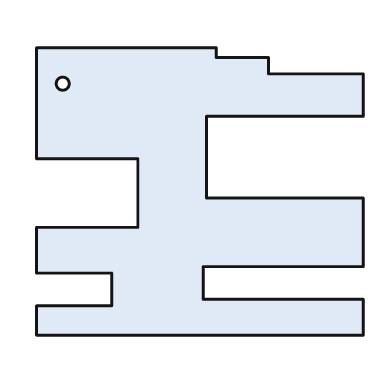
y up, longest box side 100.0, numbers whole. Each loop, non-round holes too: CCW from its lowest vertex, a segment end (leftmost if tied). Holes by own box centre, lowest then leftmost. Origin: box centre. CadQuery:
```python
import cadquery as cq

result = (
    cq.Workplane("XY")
    .moveTo(-50.0, -44.0)
    .lineTo(50.0, -44.0)
    .lineTo(50.0, -33.0)
    .lineTo(1.0, -33.0)
    .lineTo(1.0, -23.0)
    .lineTo(50.0, -23.0)
    .lineTo(50.0, -2.0)
    .lineTo(2.0, -2.0)
    .lineTo(2.0, 23.0)
    .lineTo(50.0, 23.0)
    .lineTo(50.0, 36.0)
    .lineTo(21.0, 36.0)
    .lineTo(21.0, 41.0)
    .lineTo(5.0, 41.0)
    .lineTo(5.0, 44.0)
    .lineTo(-50.0, 44.0)
    .lineTo(-50.0, 10.0)
    .lineTo(-19.0, 10.0)
    .lineTo(-19.0, -11.0)
    .lineTo(-50.0, -11.0)
    .lineTo(-50.0, -25.0)
    .lineTo(-27.0, -25.0)
    .lineTo(-27.0, -35.0)
    .lineTo(-50.0, -35.0)
    .close()
    .moveTo(-42.0, 33.0)
    .circle(2.0)
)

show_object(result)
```